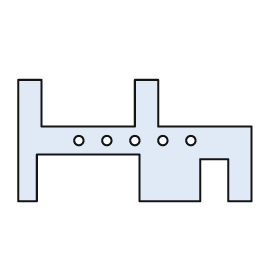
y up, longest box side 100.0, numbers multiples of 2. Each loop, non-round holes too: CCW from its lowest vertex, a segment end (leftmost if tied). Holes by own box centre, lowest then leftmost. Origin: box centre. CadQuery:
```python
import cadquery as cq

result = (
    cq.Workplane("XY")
    .moveTo(-50.0, -26.0)
    .lineTo(-42.0, -26.0)
    .lineTo(-42.0, -6.0)
    .lineTo(2.0, -6.0)
    .lineTo(2.0, -26.0)
    .lineTo(28.0, -26.0)
    .lineTo(28.0, -8.0)
    .lineTo(40.0, -8.0)
    .lineTo(40.0, -26.0)
    .lineTo(50.0, -26.0)
    .lineTo(50.0, 6.0)
    .lineTo(10.0, 6.0)
    .lineTo(10.0, 26.0)
    .lineTo(0.0, 26.0)
    .lineTo(0.0, 6.0)
    .lineTo(-40.0, 6.0)
    .lineTo(-40.0, 26.0)
    .lineTo(-50.0, 26.0)
    .close()
    .moveTo(-24.0, 0.0)
    .circle(2.0)
    .moveTo(-12.0, 0.0)
    .circle(2.0)
    .moveTo(0.0, 0.0)
    .circle(2.0)
    .moveTo(12.0, 0.0)
    .circle(2.0)
    .moveTo(24.0, 0.0)
    .circle(2.0)
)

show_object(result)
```